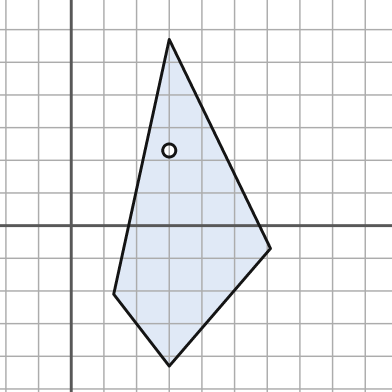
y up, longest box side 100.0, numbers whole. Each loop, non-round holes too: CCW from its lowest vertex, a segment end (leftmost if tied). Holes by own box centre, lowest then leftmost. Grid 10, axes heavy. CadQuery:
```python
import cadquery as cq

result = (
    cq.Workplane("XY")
    .moveTo(30.0, -43.0)
    .lineTo(61.0, -7.0)
    .lineTo(30.0, 57.0)
    .lineTo(13.0, -21.0)
    .close()
    .moveTo(30.0, 23.0)
    .circle(2.0)
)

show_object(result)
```